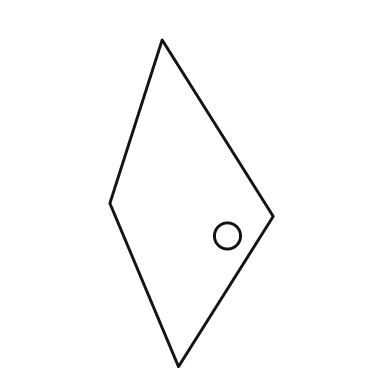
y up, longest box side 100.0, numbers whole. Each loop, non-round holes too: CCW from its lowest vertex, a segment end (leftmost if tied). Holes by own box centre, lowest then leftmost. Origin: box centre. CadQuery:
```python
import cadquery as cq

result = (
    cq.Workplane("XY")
    .moveTo(-4.0, -50.0)
    .lineTo(25.0, -4.0)
    .lineTo(-9.0, 50.0)
    .lineTo(-25.0, 0.0)
    .close()
    .moveTo(11.0, -10.0)
    .circle(4.0)
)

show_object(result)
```